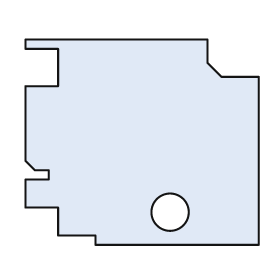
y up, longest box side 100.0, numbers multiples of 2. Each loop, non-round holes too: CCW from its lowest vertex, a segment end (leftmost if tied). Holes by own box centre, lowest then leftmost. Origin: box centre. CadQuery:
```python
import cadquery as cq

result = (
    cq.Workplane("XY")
    .moveTo(-20.0, -44.0)
    .lineTo(50.0, -44.0)
    .lineTo(50.0, 28.0)
    .lineTo(34.0, 28.0)
    .lineTo(28.0, 34.0)
    .lineTo(28.0, 44.0)
    .lineTo(-50.0, 44.0)
    .lineTo(-50.0, 40.0)
    .lineTo(-36.0, 40.0)
    .lineTo(-36.0, 24.0)
    .lineTo(-50.0, 24.0)
    .lineTo(-50.0, -8.0)
    .lineTo(-46.0, -12.0)
    .lineTo(-40.0, -12.0)
    .lineTo(-40.0, -16.0)
    .lineTo(-50.0, -16.0)
    .lineTo(-50.0, -28.0)
    .lineTo(-36.0, -28.0)
    .lineTo(-36.0, -40.0)
    .lineTo(-20.0, -40.0)
    .close()
    .moveTo(12.0, -30.0)
    .circle(8.0)
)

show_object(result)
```